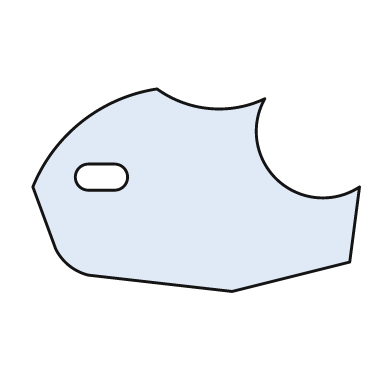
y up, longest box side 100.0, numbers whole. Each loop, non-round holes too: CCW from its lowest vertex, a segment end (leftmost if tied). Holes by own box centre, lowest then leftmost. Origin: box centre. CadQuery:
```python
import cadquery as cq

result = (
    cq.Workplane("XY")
    .moveTo(11.0, -31.0)
    .lineTo(47.0, -22.0)
    .lineTo(50.0, 1.0)
    .threePointArc((25.0, 3.0), (21.0, 28.0))
    .threePointArc((4.0, 25.0), (-12.0, 31.0))
    .threePointArc((-35.0, 21.0), (-50.0, 1.0))
    .lineTo(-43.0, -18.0)
    .threePointArc((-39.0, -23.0), (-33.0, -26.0))
    .close()
    .moveTo(-33.0, 0.0)
    .lineTo(-25.0, 0.0)
    .threePointArc((-21.0, 4.0), (-25.0, 8.0))
    .lineTo(-33.0, 8.0)
    .threePointArc((-37.0, 4.0), (-33.0, 0.0))
    .close()
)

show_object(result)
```